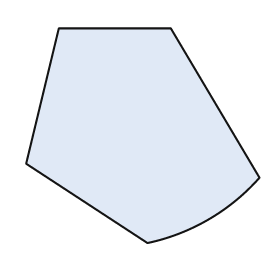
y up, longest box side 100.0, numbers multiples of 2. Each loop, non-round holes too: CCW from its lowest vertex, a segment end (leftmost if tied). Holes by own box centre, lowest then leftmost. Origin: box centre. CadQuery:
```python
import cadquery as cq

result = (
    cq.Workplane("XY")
    .moveTo(2.0, -46.0)
    .threePointArc((28.0, -36.0), (50.0, -18.0))
    .lineTo(12.0, 46.0)
    .lineTo(-36.0, 46.0)
    .lineTo(-50.0, -12.0)
    .close()
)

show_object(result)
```